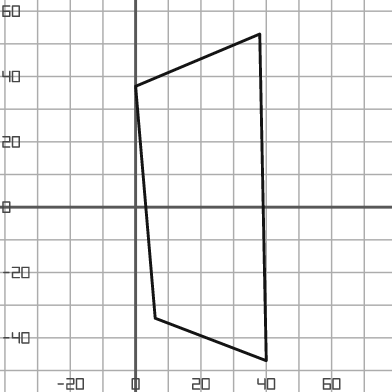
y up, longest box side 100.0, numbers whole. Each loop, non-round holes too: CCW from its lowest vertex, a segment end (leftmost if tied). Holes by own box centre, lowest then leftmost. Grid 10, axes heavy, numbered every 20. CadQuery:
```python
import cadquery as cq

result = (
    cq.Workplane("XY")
    .moveTo(40.0, -47.0)
    .lineTo(38.0, 53.0)
    .lineTo(0.0, 37.0)
    .lineTo(6.0, -34.0)
    .close()
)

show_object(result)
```